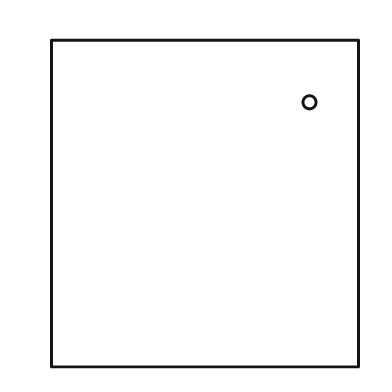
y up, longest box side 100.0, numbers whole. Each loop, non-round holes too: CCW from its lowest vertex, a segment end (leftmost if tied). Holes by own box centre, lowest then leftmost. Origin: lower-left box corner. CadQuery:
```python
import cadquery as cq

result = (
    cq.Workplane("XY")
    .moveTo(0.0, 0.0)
    .lineTo(94.0, 0.0)
    .lineTo(94.0, 100.0)
    .lineTo(0.0, 100.0)
    .close()
    .moveTo(79.0, 81.0)
    .circle(2.0)
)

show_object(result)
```